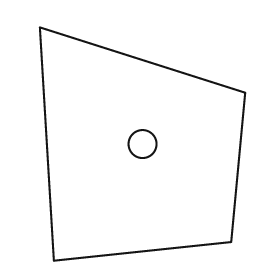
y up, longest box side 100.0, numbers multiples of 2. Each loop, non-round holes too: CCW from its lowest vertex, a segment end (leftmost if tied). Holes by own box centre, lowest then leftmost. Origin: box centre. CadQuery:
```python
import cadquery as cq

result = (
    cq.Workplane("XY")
    .moveTo(-38.0, -50.0)
    .lineTo(38.0, -42.0)
    .lineTo(44.0, 22.0)
    .lineTo(-44.0, 50.0)
    .close()
    .moveTo(0.0, 0.0)
    .circle(6.0)
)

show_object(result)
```